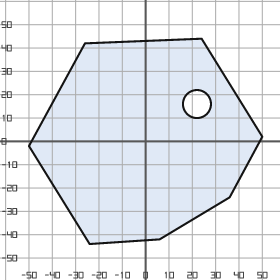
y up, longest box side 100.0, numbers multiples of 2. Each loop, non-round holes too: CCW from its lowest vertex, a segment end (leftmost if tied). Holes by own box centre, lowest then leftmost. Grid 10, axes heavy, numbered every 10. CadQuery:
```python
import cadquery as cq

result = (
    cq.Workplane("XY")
    .moveTo(-24.0, -44.0)
    .lineTo(6.0, -42.0)
    .lineTo(36.0, -24.0)
    .lineTo(50.0, 2.0)
    .lineTo(24.0, 44.0)
    .lineTo(-26.0, 42.0)
    .lineTo(-50.0, -2.0)
    .close()
    .moveTo(22.0, 16.0)
    .circle(6.0)
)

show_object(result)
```